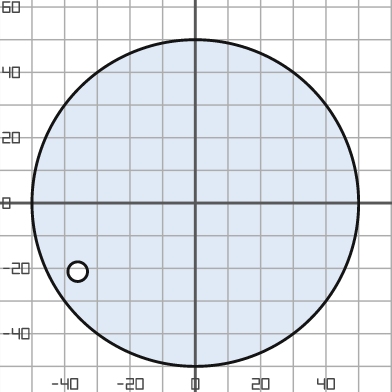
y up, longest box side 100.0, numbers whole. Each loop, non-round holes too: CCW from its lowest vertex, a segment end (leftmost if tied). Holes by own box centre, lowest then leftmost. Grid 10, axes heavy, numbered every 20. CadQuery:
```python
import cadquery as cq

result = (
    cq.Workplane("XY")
    .moveTo(0.0, 0.0)
    .circle(50.0)
    .moveTo(-36.0, -21.0)
    .circle(3.0)
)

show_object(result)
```